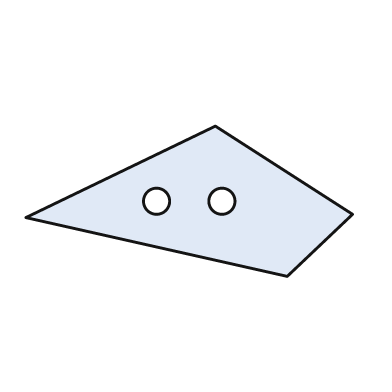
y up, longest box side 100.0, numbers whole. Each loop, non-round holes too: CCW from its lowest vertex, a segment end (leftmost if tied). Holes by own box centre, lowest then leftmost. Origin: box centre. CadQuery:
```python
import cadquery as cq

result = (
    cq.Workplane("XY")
    .moveTo(30.0, -23.0)
    .lineTo(50.0, -4.0)
    .lineTo(8.0, 23.0)
    .lineTo(-50.0, -5.0)
    .close()
    .moveTo(-10.0, 0.0)
    .circle(4.0)
    .moveTo(10.0, 0.0)
    .circle(4.0)
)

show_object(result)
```